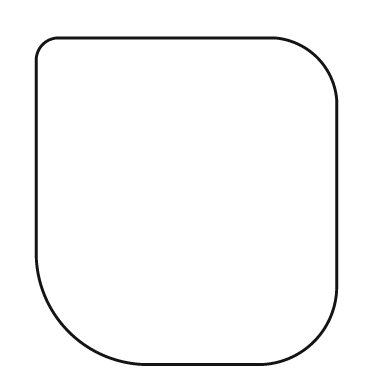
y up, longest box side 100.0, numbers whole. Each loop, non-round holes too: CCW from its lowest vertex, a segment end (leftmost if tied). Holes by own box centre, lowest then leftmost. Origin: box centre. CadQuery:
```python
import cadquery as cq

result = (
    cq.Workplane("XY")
    .moveTo(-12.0, -50.0)
    .lineTo(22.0, -50.0)
    .threePointArc((39.0, -43.0), (46.0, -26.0))
    .lineTo(46.0, 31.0)
    .threePointArc((40.0, 44.0), (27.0, 50.0))
    .lineTo(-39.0, 50.0)
    .threePointArc((-44.0, 48.0), (-46.0, 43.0))
    .lineTo(-46.0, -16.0)
    .threePointArc((-36.0, -40.0), (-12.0, -50.0))
    .close()
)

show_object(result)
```